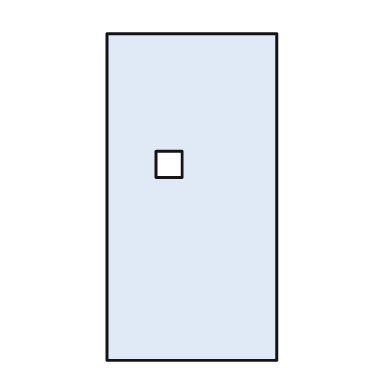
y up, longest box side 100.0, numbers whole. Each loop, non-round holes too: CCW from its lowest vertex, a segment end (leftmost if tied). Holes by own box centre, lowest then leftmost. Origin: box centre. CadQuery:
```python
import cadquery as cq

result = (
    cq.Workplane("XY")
    .moveTo(-26.0, -50.0)
    .lineTo(26.0, -50.0)
    .lineTo(26.0, 50.0)
    .lineTo(-26.0, 50.0)
    .close()
    .moveTo(-11.0, 6.0)
    .lineTo(-3.0, 6.0)
    .lineTo(-3.0, 14.0)
    .lineTo(-11.0, 14.0)
    .close()
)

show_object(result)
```